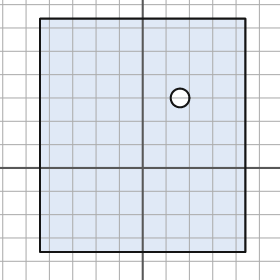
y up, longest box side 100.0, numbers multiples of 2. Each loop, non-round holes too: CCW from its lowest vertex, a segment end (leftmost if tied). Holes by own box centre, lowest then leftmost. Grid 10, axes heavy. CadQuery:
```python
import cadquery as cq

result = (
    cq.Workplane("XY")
    .moveTo(-44.0, -36.0)
    .lineTo(44.0, -36.0)
    .lineTo(44.0, 64.0)
    .lineTo(-44.0, 64.0)
    .close()
    .moveTo(16.0, 30.0)
    .circle(4.0)
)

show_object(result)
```